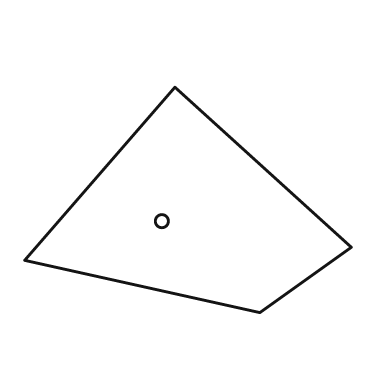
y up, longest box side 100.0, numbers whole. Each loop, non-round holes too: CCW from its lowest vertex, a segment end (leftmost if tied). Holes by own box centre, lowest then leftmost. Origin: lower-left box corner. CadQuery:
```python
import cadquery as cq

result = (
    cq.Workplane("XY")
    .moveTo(72.0, 0.0)
    .lineTo(100.0, 20.0)
    .lineTo(46.0, 69.0)
    .lineTo(0.0, 16.0)
    .close()
    .moveTo(42.0, 28.0)
    .circle(2.0)
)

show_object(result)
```